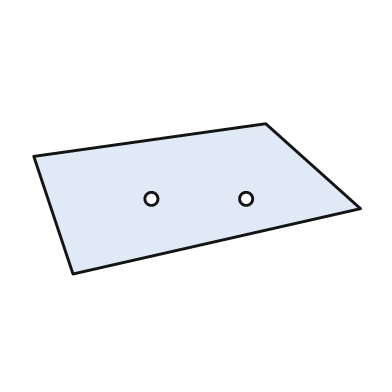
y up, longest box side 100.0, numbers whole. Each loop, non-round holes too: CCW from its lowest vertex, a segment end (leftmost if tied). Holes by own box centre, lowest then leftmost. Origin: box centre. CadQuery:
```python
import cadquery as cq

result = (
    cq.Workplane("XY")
    .moveTo(-38.0, -23.0)
    .lineTo(50.0, -3.0)
    .lineTo(21.0, 23.0)
    .lineTo(-50.0, 13.0)
    .close()
    .moveTo(-14.0, 0.0)
    .circle(2.0)
    .moveTo(15.0, 0.0)
    .circle(2.0)
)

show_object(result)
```